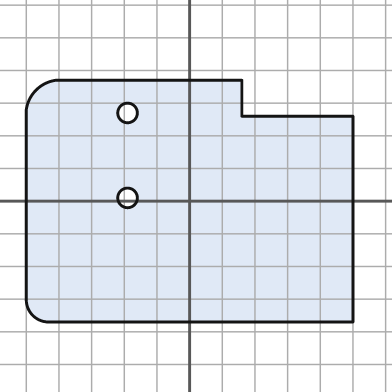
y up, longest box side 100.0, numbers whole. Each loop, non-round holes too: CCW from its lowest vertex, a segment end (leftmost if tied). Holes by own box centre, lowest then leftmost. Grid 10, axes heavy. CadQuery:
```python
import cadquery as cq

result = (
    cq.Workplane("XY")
    .moveTo(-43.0, -37.0)
    .lineTo(50.0, -37.0)
    .lineTo(50.0, 26.0)
    .lineTo(16.0, 26.0)
    .lineTo(16.0, 37.0)
    .lineTo(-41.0, 37.0)
    .threePointArc((-47.0, 34.0), (-50.0, 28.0))
    .lineTo(-50.0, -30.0)
    .threePointArc((-48.0, -35.0), (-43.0, -37.0))
    .close()
    .moveTo(-19.0, 1.0)
    .circle(3.0)
    .moveTo(-19.0, 27.0)
    .circle(3.0)
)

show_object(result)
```